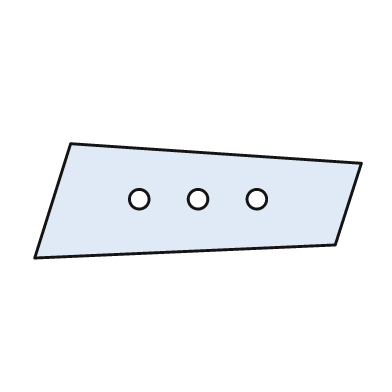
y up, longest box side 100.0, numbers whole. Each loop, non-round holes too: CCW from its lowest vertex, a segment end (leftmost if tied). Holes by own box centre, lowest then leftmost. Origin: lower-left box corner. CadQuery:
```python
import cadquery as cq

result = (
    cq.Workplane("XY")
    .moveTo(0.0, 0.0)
    .lineTo(92.0, 4.0)
    .lineTo(100.0, 29.0)
    .lineTo(11.0, 35.0)
    .close()
    .moveTo(32.0, 18.0)
    .circle(3.0)
    .moveTo(50.0, 18.0)
    .circle(3.0)
    .moveTo(68.0, 18.0)
    .circle(3.0)
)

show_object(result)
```